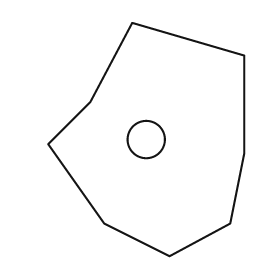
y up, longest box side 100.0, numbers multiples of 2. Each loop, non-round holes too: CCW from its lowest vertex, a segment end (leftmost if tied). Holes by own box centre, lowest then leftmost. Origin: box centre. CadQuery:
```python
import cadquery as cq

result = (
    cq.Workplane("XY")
    .moveTo(10.0, -50.0)
    .lineTo(36.0, -36.0)
    .lineTo(42.0, -6.0)
    .lineTo(42.0, 36.0)
    .lineTo(-6.0, 50.0)
    .lineTo(-24.0, 16.0)
    .lineTo(-42.0, -2.0)
    .lineTo(-18.0, -36.0)
    .close()
    .moveTo(0.0, 0.0)
    .circle(8.0)
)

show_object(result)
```